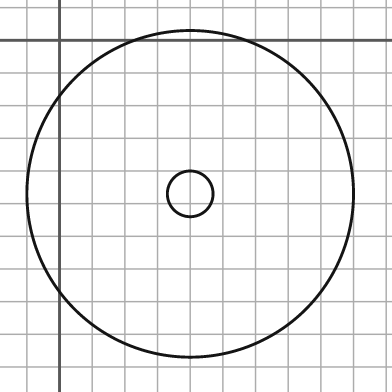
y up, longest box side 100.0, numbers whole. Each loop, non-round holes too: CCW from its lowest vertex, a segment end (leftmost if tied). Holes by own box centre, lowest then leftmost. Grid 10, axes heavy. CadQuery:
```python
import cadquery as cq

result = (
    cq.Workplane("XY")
    .moveTo(40.0, -47.0)
    .circle(50.0)
    .moveTo(40.0, -47.0)
    .circle(7.0)
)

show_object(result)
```